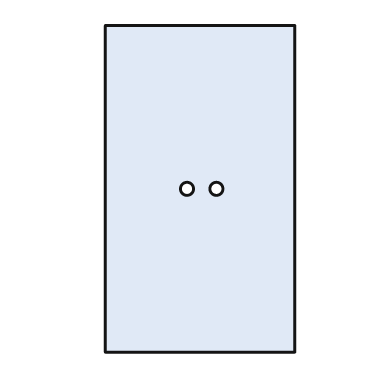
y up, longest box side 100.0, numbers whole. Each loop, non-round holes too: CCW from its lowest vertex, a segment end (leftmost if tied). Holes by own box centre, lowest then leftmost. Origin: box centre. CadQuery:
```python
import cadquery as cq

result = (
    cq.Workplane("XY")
    .moveTo(-29.0, -50.0)
    .lineTo(29.0, -50.0)
    .lineTo(29.0, 50.0)
    .lineTo(-29.0, 50.0)
    .close()
    .moveTo(-4.0, 0.0)
    .circle(2.0)
    .moveTo(5.0, 0.0)
    .circle(2.0)
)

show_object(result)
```